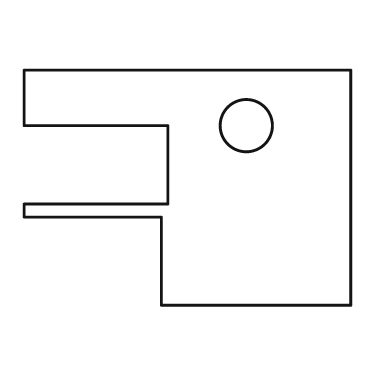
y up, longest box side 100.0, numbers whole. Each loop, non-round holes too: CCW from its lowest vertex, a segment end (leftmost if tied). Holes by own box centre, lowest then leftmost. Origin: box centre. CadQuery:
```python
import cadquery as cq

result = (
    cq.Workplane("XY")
    .moveTo(-8.0, -36.0)
    .lineTo(50.0, -36.0)
    .lineTo(50.0, 36.0)
    .lineTo(-50.0, 36.0)
    .lineTo(-50.0, 19.0)
    .lineTo(-6.0, 19.0)
    .lineTo(-6.0, -5.0)
    .lineTo(-50.0, -5.0)
    .lineTo(-50.0, -9.0)
    .lineTo(-8.0, -9.0)
    .close()
    .moveTo(18.0, 19.0)
    .circle(8.0)
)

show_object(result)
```